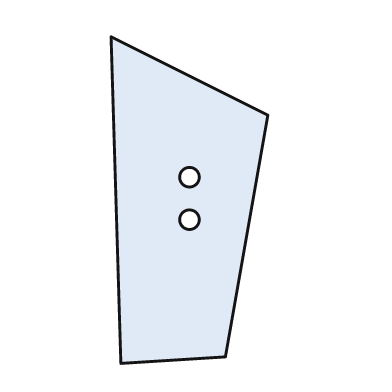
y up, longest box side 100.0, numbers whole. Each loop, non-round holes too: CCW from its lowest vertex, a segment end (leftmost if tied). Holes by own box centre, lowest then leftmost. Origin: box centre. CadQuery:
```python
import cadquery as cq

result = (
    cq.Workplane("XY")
    .moveTo(-21.0, -50.0)
    .lineTo(11.0, -48.0)
    .lineTo(24.0, 26.0)
    .lineTo(-24.0, 50.0)
    .close()
    .moveTo(0.0, -6.0)
    .circle(3.0)
    .moveTo(0.0, 7.0)
    .circle(3.0)
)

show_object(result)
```